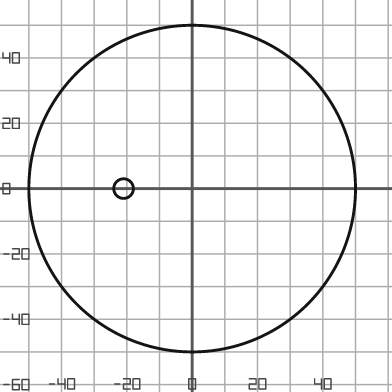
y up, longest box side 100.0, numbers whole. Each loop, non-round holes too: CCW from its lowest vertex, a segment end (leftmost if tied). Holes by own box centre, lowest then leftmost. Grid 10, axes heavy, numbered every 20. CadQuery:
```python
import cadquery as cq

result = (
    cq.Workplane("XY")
    .moveTo(0.0, 0.0)
    .circle(50.0)
    .moveTo(-21.0, 0.0)
    .circle(3.0)
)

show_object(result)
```